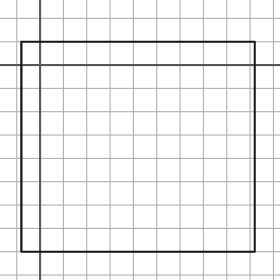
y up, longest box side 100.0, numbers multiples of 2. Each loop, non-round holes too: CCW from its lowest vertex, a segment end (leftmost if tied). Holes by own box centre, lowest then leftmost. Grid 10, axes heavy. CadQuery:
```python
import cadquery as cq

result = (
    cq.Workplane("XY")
    .moveTo(-8.0, -80.0)
    .lineTo(92.0, -80.0)
    .lineTo(92.0, 10.0)
    .lineTo(-8.0, 10.0)
    .close()
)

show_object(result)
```